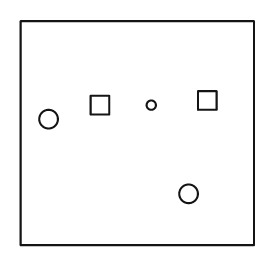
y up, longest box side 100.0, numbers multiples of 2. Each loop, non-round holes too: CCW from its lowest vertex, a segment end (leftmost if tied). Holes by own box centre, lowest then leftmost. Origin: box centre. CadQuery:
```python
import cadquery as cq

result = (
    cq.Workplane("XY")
    .moveTo(-50.0, -48.0)
    .lineTo(50.0, -48.0)
    .lineTo(50.0, 48.0)
    .lineTo(-50.0, 48.0)
    .close()
    .moveTo(22.0, -26.0)
    .circle(4.0)
    .moveTo(-38.0, 6.0)
    .circle(4.0)
    .moveTo(-20.0, 8.0)
    .lineTo(-12.0, 8.0)
    .lineTo(-12.0, 16.0)
    .lineTo(-20.0, 16.0)
    .close()
    .moveTo(6.0, 12.0)
    .circle(2.0)
    .moveTo(26.0, 10.0)
    .lineTo(34.0, 10.0)
    .lineTo(34.0, 18.0)
    .lineTo(26.0, 18.0)
    .close()
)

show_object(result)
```